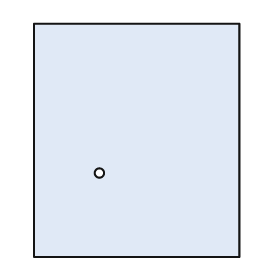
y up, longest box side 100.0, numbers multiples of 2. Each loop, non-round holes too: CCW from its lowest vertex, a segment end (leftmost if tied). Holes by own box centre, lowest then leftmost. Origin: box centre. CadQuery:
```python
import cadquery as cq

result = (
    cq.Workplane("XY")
    .moveTo(-44.0, -50.0)
    .lineTo(44.0, -50.0)
    .lineTo(44.0, 50.0)
    .lineTo(-44.0, 50.0)
    .close()
    .moveTo(-16.0, -14.0)
    .circle(2.0)
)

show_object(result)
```